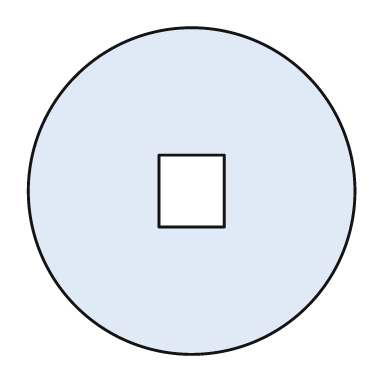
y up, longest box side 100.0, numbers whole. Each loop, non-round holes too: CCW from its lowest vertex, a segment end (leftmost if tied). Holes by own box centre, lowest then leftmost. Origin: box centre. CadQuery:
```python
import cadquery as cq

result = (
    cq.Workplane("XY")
    .moveTo(0.0, 0.0)
    .circle(50.0)
    .moveTo(-10.0, -11.0)
    .lineTo(10.0, -11.0)
    .lineTo(10.0, 11.0)
    .lineTo(-10.0, 11.0)
    .close()
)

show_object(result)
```